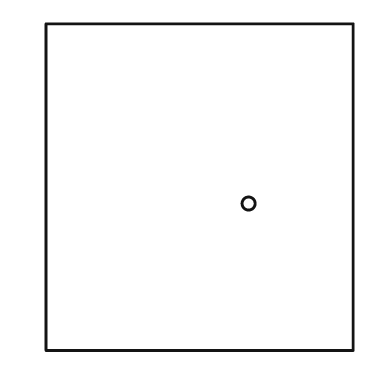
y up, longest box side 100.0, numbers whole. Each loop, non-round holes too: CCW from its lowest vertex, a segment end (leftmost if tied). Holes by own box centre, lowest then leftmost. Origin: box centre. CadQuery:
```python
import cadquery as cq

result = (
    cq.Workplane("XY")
    .moveTo(-47.0, -50.0)
    .lineTo(47.0, -50.0)
    .lineTo(47.0, 50.0)
    .lineTo(-47.0, 50.0)
    .close()
    .moveTo(15.0, -5.0)
    .circle(2.0)
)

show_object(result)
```